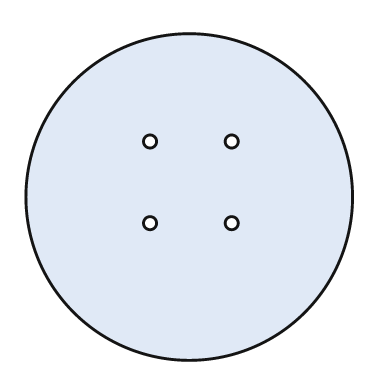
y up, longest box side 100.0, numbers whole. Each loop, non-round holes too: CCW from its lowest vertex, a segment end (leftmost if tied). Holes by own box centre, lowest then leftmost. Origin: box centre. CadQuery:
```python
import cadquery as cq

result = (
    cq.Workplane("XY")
    .moveTo(0.0, 0.0)
    .circle(50.0)
    .moveTo(-12.0, -8.0)
    .circle(2.0)
    .moveTo(13.0, -8.0)
    .circle(2.0)
    .moveTo(-12.0, 17.0)
    .circle(2.0)
    .moveTo(13.0, 17.0)
    .circle(2.0)
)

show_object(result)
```